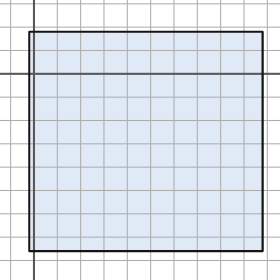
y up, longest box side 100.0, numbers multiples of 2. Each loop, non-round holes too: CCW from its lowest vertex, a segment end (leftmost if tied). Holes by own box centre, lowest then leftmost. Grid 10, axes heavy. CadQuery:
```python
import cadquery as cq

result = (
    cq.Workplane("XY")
    .moveTo(-2.0, -76.0)
    .lineTo(98.0, -76.0)
    .lineTo(98.0, 18.0)
    .lineTo(-2.0, 18.0)
    .close()
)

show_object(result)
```